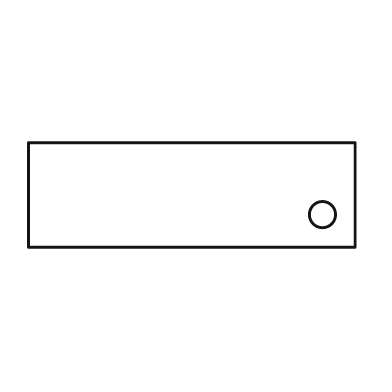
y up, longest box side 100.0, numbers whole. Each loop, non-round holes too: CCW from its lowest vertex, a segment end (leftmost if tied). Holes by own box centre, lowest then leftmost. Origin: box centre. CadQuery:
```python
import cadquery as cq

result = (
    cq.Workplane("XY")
    .moveTo(-50.0, -16.0)
    .lineTo(50.0, -16.0)
    .lineTo(50.0, 16.0)
    .lineTo(-50.0, 16.0)
    .close()
    .moveTo(40.0, -6.0)
    .circle(4.0)
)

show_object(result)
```